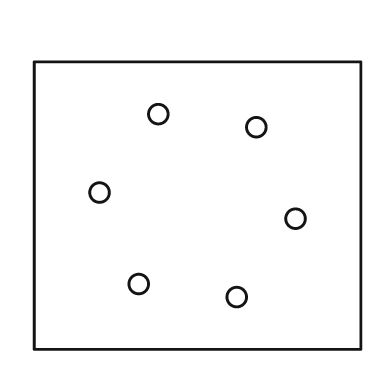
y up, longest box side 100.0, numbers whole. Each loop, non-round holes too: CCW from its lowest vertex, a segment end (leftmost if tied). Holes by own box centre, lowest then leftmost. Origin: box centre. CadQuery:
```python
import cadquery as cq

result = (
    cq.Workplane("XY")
    .moveTo(-50.0, -44.0)
    .lineTo(50.0, -44.0)
    .lineTo(50.0, 44.0)
    .lineTo(-50.0, 44.0)
    .close()
    .moveTo(12.0, -28.0)
    .circle(3.0)
    .moveTo(-18.0, -24.0)
    .circle(3.0)
    .moveTo(30.0, -4.0)
    .circle(3.0)
    .moveTo(-30.0, 4.0)
    .circle(3.0)
    .moveTo(18.0, 24.0)
    .circle(3.0)
    .moveTo(-12.0, 28.0)
    .circle(3.0)
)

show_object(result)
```